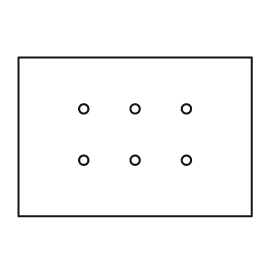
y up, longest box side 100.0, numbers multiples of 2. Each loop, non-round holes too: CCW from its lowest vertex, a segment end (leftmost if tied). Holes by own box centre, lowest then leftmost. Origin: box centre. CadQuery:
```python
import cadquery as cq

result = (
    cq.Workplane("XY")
    .moveTo(-50.0, -34.0)
    .lineTo(50.0, -34.0)
    .lineTo(50.0, 34.0)
    .lineTo(-50.0, 34.0)
    .close()
    .moveTo(-22.0, -10.0)
    .circle(2.0)
    .moveTo(0.0, -10.0)
    .circle(2.0)
    .moveTo(22.0, -10.0)
    .circle(2.0)
    .moveTo(-22.0, 12.0)
    .circle(2.0)
    .moveTo(0.0, 12.0)
    .circle(2.0)
    .moveTo(22.0, 12.0)
    .circle(2.0)
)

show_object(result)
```